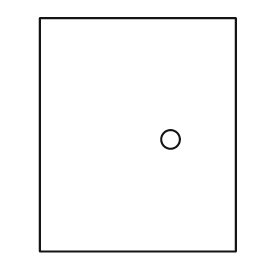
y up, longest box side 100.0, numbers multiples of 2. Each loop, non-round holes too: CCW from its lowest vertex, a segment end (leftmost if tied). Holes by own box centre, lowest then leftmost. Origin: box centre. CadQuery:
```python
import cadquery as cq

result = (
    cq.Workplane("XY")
    .moveTo(-42.0, -50.0)
    .lineTo(42.0, -50.0)
    .lineTo(42.0, 50.0)
    .lineTo(-42.0, 50.0)
    .close()
    .moveTo(14.0, -2.0)
    .circle(4.0)
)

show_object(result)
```